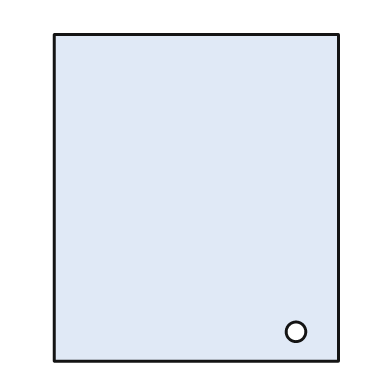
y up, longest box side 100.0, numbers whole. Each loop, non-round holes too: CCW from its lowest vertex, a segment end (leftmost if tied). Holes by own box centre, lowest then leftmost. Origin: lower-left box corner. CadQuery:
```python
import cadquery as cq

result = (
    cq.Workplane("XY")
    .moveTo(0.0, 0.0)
    .lineTo(87.0, 0.0)
    .lineTo(87.0, 100.0)
    .lineTo(0.0, 100.0)
    .close()
    .moveTo(74.0, 9.0)
    .circle(3.0)
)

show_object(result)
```